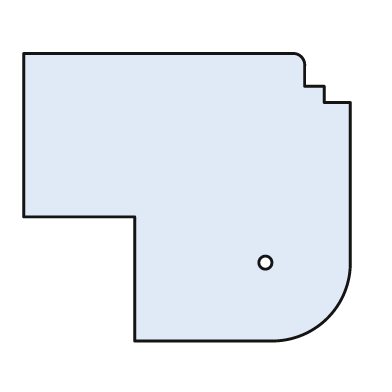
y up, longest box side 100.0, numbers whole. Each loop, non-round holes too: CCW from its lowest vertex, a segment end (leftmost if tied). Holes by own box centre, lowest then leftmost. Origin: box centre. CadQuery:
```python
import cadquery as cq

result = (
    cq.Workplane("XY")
    .moveTo(-16.0, -44.0)
    .lineTo(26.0, -44.0)
    .threePointArc((43.0, -37.0), (50.0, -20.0))
    .lineTo(50.0, 29.0)
    .lineTo(42.0, 29.0)
    .lineTo(42.0, 34.0)
    .lineTo(36.0, 34.0)
    .lineTo(36.0, 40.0)
    .threePointArc((35.0, 43.0), (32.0, 44.0))
    .lineTo(-50.0, 44.0)
    .lineTo(-50.0, -6.0)
    .lineTo(-16.0, -6.0)
    .close()
    .moveTo(24.0, -20.0)
    .circle(2.0)
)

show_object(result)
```